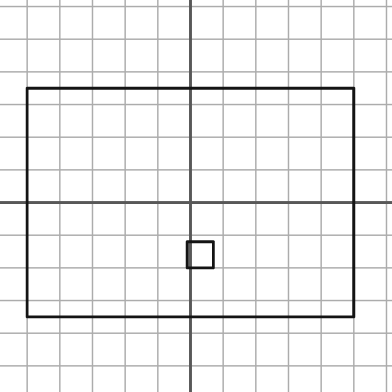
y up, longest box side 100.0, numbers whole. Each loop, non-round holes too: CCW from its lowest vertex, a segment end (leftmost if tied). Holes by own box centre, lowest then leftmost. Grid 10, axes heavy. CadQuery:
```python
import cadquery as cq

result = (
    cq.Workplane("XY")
    .moveTo(-50.0, -35.0)
    .lineTo(50.0, -35.0)
    .lineTo(50.0, 35.0)
    .lineTo(-50.0, 35.0)
    .close()
    .moveTo(-1.0, -20.0)
    .lineTo(7.0, -20.0)
    .lineTo(7.0, -12.0)
    .lineTo(-1.0, -12.0)
    .close()
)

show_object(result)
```